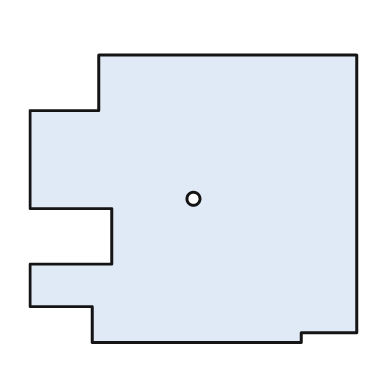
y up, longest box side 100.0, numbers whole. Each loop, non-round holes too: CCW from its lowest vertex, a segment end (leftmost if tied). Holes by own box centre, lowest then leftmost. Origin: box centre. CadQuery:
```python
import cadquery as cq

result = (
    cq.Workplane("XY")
    .moveTo(-31.0, -44.0)
    .lineTo(33.0, -44.0)
    .lineTo(33.0, -41.0)
    .lineTo(50.0, -41.0)
    .lineTo(50.0, 44.0)
    .lineTo(-29.0, 44.0)
    .lineTo(-29.0, 27.0)
    .lineTo(-50.0, 27.0)
    .lineTo(-50.0, -3.0)
    .lineTo(-25.0, -3.0)
    .lineTo(-25.0, -20.0)
    .lineTo(-50.0, -20.0)
    .lineTo(-50.0, -33.0)
    .lineTo(-31.0, -33.0)
    .close()
    .moveTo(0.0, 0.0)
    .circle(2.0)
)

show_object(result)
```